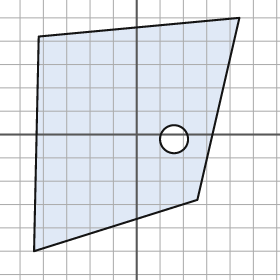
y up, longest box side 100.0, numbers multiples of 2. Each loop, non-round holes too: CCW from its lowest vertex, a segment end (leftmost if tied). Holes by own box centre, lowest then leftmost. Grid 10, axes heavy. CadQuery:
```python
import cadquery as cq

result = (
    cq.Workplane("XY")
    .moveTo(-44.0, -50.0)
    .lineTo(26.0, -28.0)
    .lineTo(44.0, 50.0)
    .lineTo(-42.0, 42.0)
    .close()
    .moveTo(16.0, -2.0)
    .circle(6.0)
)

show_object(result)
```